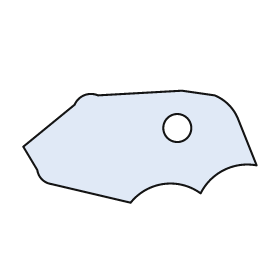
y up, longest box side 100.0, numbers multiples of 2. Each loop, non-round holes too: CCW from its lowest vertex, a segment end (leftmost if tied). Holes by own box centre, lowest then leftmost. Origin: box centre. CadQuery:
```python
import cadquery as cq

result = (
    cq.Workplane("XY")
    .moveTo(-4.0, -24.0)
    .threePointArc((10.0, -16.0), (26.0, -20.0))
    .threePointArc((36.0, -10.0), (50.0, -8.0))
    .lineTo(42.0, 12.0)
    .threePointArc((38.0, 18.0), (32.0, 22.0))
    .lineTo(18.0, 24.0)
    .lineTo(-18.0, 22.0)
    .threePointArc((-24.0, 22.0), (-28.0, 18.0))
    .lineTo(-50.0, 0.0)
    .lineTo(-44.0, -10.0)
    .threePointArc((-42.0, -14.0), (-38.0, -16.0))
    .close()
    .moveTo(16.0, 8.0)
    .circle(6.0)
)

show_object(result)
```